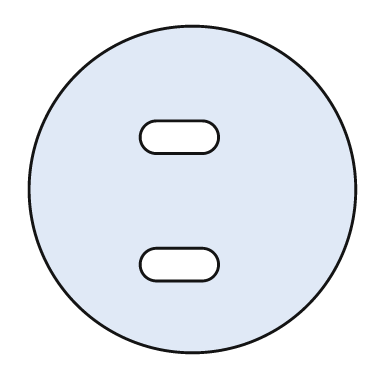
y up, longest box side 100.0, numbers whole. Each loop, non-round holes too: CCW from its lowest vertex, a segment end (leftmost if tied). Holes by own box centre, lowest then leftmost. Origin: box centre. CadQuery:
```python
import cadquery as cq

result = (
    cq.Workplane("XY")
    .moveTo(0.0, 0.0)
    .circle(50.0)
    .moveTo(-11.0, -28.0)
    .lineTo(3.0, -28.0)
    .threePointArc((8.0, -23.0), (3.0, -18.0))
    .lineTo(-11.0, -18.0)
    .threePointArc((-16.0, -23.0), (-11.0, -28.0))
    .close()
    .moveTo(-11.0, 11.0)
    .lineTo(3.0, 11.0)
    .threePointArc((8.0, 16.0), (3.0, 21.0))
    .lineTo(-11.0, 21.0)
    .threePointArc((-16.0, 16.0), (-11.0, 11.0))
    .close()
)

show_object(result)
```